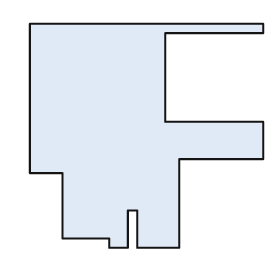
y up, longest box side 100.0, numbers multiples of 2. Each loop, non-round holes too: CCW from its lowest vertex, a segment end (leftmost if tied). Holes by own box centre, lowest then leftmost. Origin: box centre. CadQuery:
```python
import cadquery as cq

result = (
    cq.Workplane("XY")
    .moveTo(-16.0, -48.0)
    .lineTo(-8.0, -48.0)
    .lineTo(-8.0, -32.0)
    .lineTo(-4.0, -32.0)
    .lineTo(-4.0, -48.0)
    .lineTo(14.0, -48.0)
    .lineTo(14.0, -10.0)
    .lineTo(50.0, -10.0)
    .lineTo(50.0, 6.0)
    .lineTo(8.0, 6.0)
    .lineTo(8.0, 44.0)
    .lineTo(50.0, 44.0)
    .lineTo(50.0, 48.0)
    .lineTo(-50.0, 48.0)
    .lineTo(-50.0, -16.0)
    .lineTo(-36.0, -16.0)
    .lineTo(-36.0, -44.0)
    .lineTo(-16.0, -44.0)
    .close()
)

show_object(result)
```